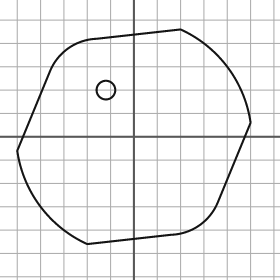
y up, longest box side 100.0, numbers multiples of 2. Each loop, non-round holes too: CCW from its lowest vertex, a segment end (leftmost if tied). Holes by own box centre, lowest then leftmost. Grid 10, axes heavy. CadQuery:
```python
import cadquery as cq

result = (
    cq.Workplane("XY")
    .moveTo(-20.0, -46.0)
    .lineTo(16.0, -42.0)
    .threePointArc((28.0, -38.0), (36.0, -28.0))
    .lineTo(50.0, 6.0)
    .threePointArc((40.0, 30.0), (20.0, 46.0))
    .lineTo(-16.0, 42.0)
    .threePointArc((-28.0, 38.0), (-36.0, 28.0))
    .lineTo(-50.0, -6.0)
    .threePointArc((-40.0, -30.0), (-20.0, -46.0))
    .close()
    .moveTo(-12.0, 20.0)
    .circle(4.0)
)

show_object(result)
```